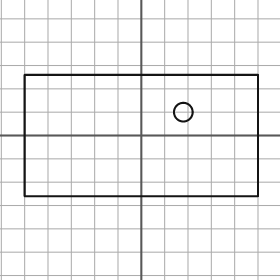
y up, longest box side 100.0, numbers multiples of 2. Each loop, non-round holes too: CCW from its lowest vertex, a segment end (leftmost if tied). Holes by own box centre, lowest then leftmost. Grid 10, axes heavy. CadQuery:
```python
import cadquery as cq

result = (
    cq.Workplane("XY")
    .moveTo(-50.0, -26.0)
    .lineTo(50.0, -26.0)
    .lineTo(50.0, 26.0)
    .lineTo(-50.0, 26.0)
    .close()
    .moveTo(18.0, 10.0)
    .circle(4.0)
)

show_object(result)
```